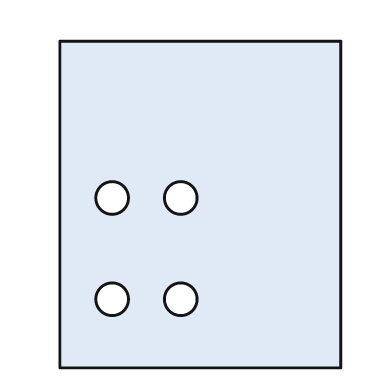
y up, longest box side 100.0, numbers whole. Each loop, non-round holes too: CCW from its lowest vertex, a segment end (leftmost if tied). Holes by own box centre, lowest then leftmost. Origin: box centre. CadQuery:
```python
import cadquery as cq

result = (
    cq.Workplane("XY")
    .moveTo(-43.0, -50.0)
    .lineTo(43.0, -50.0)
    .lineTo(43.0, 50.0)
    .lineTo(-43.0, 50.0)
    .close()
    .moveTo(-27.0, -29.0)
    .circle(5.0)
    .moveTo(-6.0, -29.0)
    .circle(5.0)
    .moveTo(-27.0, 2.0)
    .circle(5.0)
    .moveTo(-6.0, 2.0)
    .circle(5.0)
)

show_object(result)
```